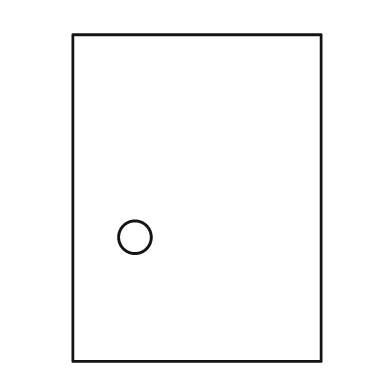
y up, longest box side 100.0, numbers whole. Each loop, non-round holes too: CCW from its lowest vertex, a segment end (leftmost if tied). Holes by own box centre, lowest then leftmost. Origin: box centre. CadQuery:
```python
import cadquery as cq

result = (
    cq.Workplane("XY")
    .moveTo(-38.0, -50.0)
    .lineTo(38.0, -50.0)
    .lineTo(38.0, 50.0)
    .lineTo(-38.0, 50.0)
    .close()
    .moveTo(-19.0, -12.0)
    .circle(5.0)
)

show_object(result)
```